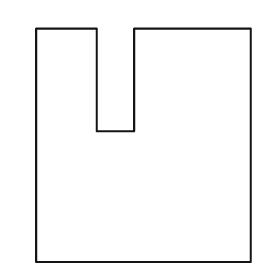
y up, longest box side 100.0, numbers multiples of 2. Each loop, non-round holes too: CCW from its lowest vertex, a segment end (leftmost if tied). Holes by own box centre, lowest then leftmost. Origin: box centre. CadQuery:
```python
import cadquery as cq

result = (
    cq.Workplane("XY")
    .moveTo(-46.0, -50.0)
    .lineTo(46.0, -50.0)
    .lineTo(46.0, 50.0)
    .lineTo(-4.0, 50.0)
    .lineTo(-4.0, 6.0)
    .lineTo(-20.0, 6.0)
    .lineTo(-20.0, 50.0)
    .lineTo(-46.0, 50.0)
    .close()
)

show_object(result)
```